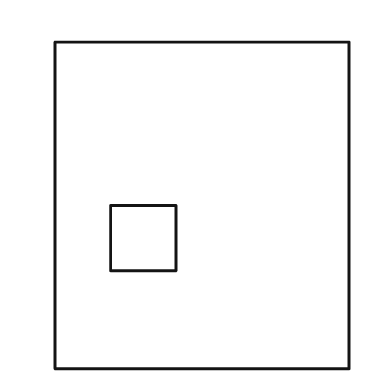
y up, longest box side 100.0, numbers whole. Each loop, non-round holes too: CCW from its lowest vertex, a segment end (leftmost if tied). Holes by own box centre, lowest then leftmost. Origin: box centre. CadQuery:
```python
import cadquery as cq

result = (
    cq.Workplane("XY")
    .moveTo(-45.0, -50.0)
    .lineTo(45.0, -50.0)
    .lineTo(45.0, 50.0)
    .lineTo(-45.0, 50.0)
    .close()
    .moveTo(-28.0, -20.0)
    .lineTo(-8.0, -20.0)
    .lineTo(-8.0, 0.0)
    .lineTo(-28.0, 0.0)
    .close()
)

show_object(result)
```